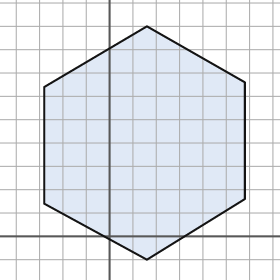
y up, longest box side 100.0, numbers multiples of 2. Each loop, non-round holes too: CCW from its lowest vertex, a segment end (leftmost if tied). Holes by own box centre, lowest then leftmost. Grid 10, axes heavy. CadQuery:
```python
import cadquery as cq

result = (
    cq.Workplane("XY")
    .moveTo(16.0, -10.0)
    .lineTo(58.0, 16.0)
    .lineTo(58.0, 66.0)
    .lineTo(16.0, 90.0)
    .lineTo(-28.0, 64.0)
    .lineTo(-28.0, 14.0)
    .close()
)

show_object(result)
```